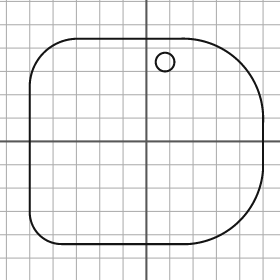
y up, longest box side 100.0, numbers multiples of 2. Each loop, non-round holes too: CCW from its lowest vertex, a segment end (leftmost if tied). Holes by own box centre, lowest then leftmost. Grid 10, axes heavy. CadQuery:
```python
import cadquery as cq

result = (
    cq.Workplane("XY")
    .moveTo(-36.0, -44.0)
    .lineTo(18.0, -44.0)
    .threePointArc((40.0, -34.0), (50.0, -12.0))
    .lineTo(50.0, 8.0)
    .threePointArc((40.0, 34.0), (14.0, 44.0))
    .lineTo(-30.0, 44.0)
    .threePointArc((-44.0, 38.0), (-50.0, 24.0))
    .lineTo(-50.0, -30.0)
    .threePointArc((-46.0, -40.0), (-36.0, -44.0))
    .close()
    .moveTo(8.0, 34.0)
    .circle(4.0)
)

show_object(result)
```